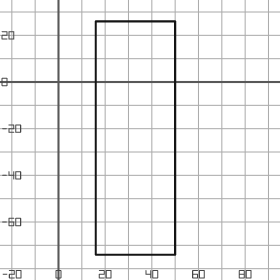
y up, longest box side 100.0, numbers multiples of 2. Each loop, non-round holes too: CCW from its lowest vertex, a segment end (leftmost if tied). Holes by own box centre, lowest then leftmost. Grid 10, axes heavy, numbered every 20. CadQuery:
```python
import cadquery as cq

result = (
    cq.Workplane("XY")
    .moveTo(16.0, -74.0)
    .lineTo(50.0, -74.0)
    .lineTo(50.0, 26.0)
    .lineTo(16.0, 26.0)
    .close()
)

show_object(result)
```